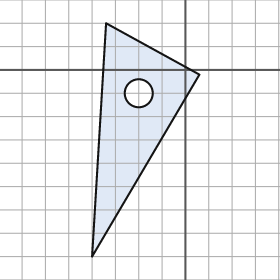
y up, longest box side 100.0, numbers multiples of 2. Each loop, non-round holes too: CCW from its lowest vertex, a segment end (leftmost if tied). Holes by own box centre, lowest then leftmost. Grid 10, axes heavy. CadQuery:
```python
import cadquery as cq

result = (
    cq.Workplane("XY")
    .moveTo(-40.0, -80.0)
    .lineTo(6.0, -2.0)
    .lineTo(-34.0, 20.0)
    .close()
    .moveTo(-20.0, -10.0)
    .circle(6.0)
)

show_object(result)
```